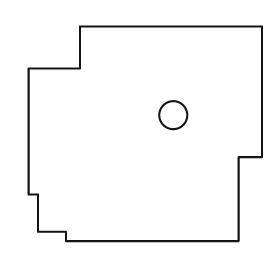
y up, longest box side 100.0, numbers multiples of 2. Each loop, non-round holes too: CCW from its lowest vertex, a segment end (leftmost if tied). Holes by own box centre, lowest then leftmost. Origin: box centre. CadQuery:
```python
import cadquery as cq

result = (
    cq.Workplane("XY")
    .moveTo(-34.0, -46.0)
    .lineTo(40.0, -46.0)
    .lineTo(40.0, -10.0)
    .lineTo(50.0, -10.0)
    .lineTo(50.0, 46.0)
    .lineTo(-28.0, 46.0)
    .lineTo(-28.0, 28.0)
    .lineTo(-50.0, 28.0)
    .lineTo(-50.0, -26.0)
    .lineTo(-46.0, -26.0)
    .lineTo(-46.0, -42.0)
    .lineTo(-34.0, -42.0)
    .close()
    .moveTo(12.0, 8.0)
    .circle(6.0)
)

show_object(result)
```